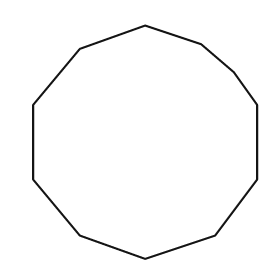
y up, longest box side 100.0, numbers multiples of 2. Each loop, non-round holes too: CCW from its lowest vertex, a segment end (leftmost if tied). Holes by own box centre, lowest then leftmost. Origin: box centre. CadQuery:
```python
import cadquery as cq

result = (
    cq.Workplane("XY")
    .moveTo(0.0, -50.0)
    .lineTo(30.0, -40.0)
    .lineTo(48.0, -16.0)
    .lineTo(48.0, 16.0)
    .lineTo(38.0, 30.0)
    .lineTo(24.0, 42.0)
    .lineTo(0.0, 50.0)
    .lineTo(-28.0, 40.0)
    .lineTo(-48.0, 16.0)
    .lineTo(-48.0, -16.0)
    .lineTo(-28.0, -40.0)
    .close()
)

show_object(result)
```